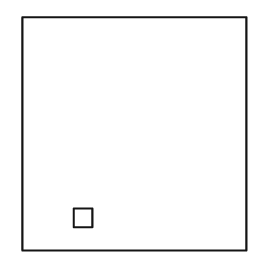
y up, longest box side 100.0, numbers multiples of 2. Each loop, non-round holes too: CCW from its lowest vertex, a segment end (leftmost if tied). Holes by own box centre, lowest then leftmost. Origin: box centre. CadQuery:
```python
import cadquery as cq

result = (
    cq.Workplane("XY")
    .moveTo(-48.0, -50.0)
    .lineTo(48.0, -50.0)
    .lineTo(48.0, 50.0)
    .lineTo(-48.0, 50.0)
    .close()
    .moveTo(-26.0, -40.0)
    .lineTo(-18.0, -40.0)
    .lineTo(-18.0, -32.0)
    .lineTo(-26.0, -32.0)
    .close()
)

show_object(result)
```